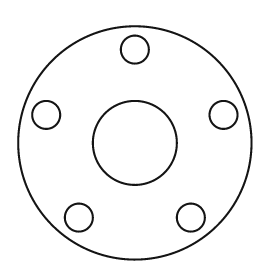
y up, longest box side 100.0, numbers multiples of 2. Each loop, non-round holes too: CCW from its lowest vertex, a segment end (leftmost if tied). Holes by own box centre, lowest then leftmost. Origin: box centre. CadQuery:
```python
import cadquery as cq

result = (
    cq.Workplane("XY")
    .moveTo(0.0, 0.0)
    .circle(50.0)
    .moveTo(-24.0, -32.0)
    .circle(6.0)
    .moveTo(24.0, -32.0)
    .circle(6.0)
    .moveTo(0.0, 0.0)
    .circle(18.0)
    .moveTo(-38.0, 12.0)
    .circle(6.0)
    .moveTo(38.0, 12.0)
    .circle(6.0)
    .moveTo(0.0, 40.0)
    .circle(6.0)
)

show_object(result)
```